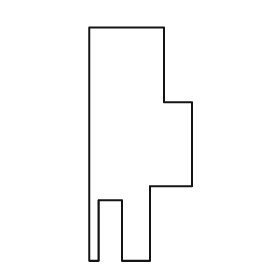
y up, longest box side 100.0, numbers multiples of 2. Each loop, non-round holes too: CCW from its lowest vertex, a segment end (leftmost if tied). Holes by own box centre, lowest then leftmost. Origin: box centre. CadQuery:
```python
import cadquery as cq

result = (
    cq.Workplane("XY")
    .moveTo(-22.0, -50.0)
    .lineTo(-18.0, -50.0)
    .lineTo(-18.0, -24.0)
    .lineTo(-8.0, -24.0)
    .lineTo(-8.0, -50.0)
    .lineTo(4.0, -50.0)
    .lineTo(4.0, -18.0)
    .lineTo(22.0, -18.0)
    .lineTo(22.0, 18.0)
    .lineTo(10.0, 18.0)
    .lineTo(10.0, 50.0)
    .lineTo(-22.0, 50.0)
    .close()
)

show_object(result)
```